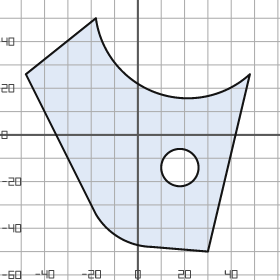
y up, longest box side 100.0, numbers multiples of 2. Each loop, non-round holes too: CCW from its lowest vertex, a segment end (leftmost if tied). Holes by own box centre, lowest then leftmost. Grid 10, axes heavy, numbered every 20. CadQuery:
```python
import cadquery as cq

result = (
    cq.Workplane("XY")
    .moveTo(30.0, -50.0)
    .lineTo(48.0, 26.0)
    .threePointArc((8.0, 18.0), (-18.0, 50.0))
    .lineTo(-48.0, 26.0)
    .lineTo(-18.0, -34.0)
    .threePointArc((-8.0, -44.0), (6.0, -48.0))
    .close()
    .moveTo(18.0, -14.0)
    .circle(8.0)
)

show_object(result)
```